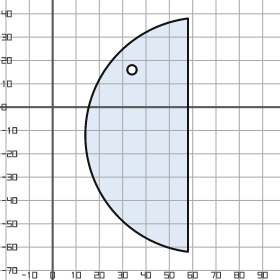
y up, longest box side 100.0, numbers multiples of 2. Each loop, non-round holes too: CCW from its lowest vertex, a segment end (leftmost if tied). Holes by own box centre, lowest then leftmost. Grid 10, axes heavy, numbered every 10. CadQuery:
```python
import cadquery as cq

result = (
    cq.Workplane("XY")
    .moveTo(58.0, -62.0)
    .lineTo(58.0, 38.0)
    .threePointArc((14.0, -12.0), (58.0, -62.0))
    .close()
    .moveTo(34.0, 16.0)
    .circle(2.0)
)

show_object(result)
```